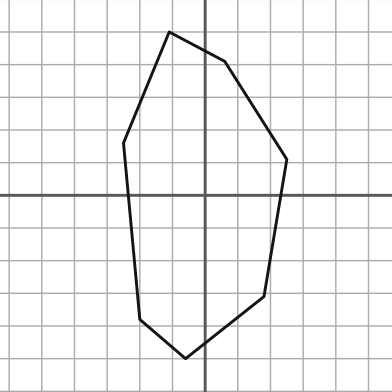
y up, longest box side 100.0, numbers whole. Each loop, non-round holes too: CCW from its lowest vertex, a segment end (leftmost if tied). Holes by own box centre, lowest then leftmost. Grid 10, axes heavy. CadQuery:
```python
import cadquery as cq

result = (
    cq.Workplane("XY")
    .moveTo(-6.0, -50.0)
    .lineTo(18.0, -31.0)
    .lineTo(25.0, 11.0)
    .lineTo(6.0, 41.0)
    .lineTo(-11.0, 50.0)
    .lineTo(-25.0, 16.0)
    .lineTo(-20.0, -38.0)
    .close()
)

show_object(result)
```